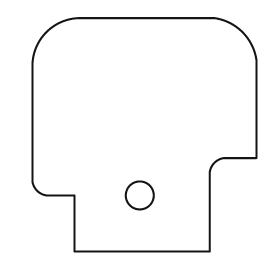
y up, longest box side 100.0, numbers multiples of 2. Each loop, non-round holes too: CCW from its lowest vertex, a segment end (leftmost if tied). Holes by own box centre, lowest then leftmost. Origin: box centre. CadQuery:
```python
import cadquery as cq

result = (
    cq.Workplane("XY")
    .moveTo(-30.0, -50.0)
    .lineTo(28.0, -50.0)
    .lineTo(28.0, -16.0)
    .threePointArc((30.0, -12.0), (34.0, -10.0))
    .lineTo(48.0, -10.0)
    .lineTo(48.0, 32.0)
    .threePointArc((42.0, 44.0), (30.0, 50.0))
    .lineTo(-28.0, 50.0)
    .threePointArc((-42.0, 44.0), (-48.0, 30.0))
    .lineTo(-48.0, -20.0)
    .threePointArc((-46.0, -24.0), (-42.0, -26.0))
    .lineTo(-30.0, -26.0)
    .close()
    .moveTo(-2.0, -26.0)
    .circle(6.0)
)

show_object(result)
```